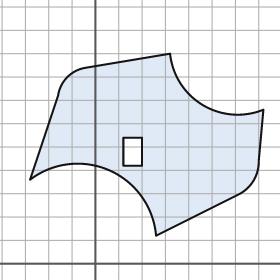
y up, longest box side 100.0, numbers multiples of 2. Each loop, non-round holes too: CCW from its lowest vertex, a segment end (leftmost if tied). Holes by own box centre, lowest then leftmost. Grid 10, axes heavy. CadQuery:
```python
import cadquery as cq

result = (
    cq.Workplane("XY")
    .moveTo(26.0, 12.0)
    .lineTo(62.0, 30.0)
    .threePointArc((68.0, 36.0), (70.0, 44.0))
    .lineTo(72.0, 66.0)
    .threePointArc((46.0, 68.0), (32.0, 90.0))
    .lineTo(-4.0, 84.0)
    .threePointArc((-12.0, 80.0), (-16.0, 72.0))
    .lineTo(-28.0, 36.0)
    .threePointArc((6.0, 40.0), (26.0, 12.0))
    .close()
    .moveTo(12.0, 42.0)
    .lineTo(20.0, 42.0)
    .lineTo(20.0, 54.0)
    .lineTo(12.0, 54.0)
    .close()
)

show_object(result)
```